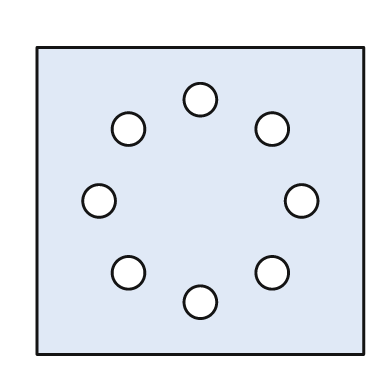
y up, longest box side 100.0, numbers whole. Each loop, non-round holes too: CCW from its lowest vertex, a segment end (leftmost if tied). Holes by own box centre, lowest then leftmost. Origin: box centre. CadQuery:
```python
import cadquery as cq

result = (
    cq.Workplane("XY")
    .moveTo(-50.0, -47.0)
    .lineTo(50.0, -47.0)
    .lineTo(50.0, 47.0)
    .lineTo(-50.0, 47.0)
    .close()
    .moveTo(0.0, -31.0)
    .circle(5.0)
    .moveTo(-22.0, -22.0)
    .circle(5.0)
    .moveTo(22.0, -22.0)
    .circle(5.0)
    .moveTo(-31.0, 0.0)
    .circle(5.0)
    .moveTo(31.0, 0.0)
    .circle(5.0)
    .moveTo(-22.0, 22.0)
    .circle(5.0)
    .moveTo(22.0, 22.0)
    .circle(5.0)
    .moveTo(0.0, 31.0)
    .circle(5.0)
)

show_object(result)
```